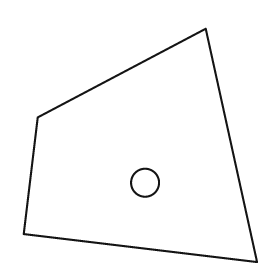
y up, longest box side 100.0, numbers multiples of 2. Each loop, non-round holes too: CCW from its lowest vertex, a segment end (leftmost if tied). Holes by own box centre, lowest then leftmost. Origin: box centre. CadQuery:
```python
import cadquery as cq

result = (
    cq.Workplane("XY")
    .moveTo(50.0, -50.0)
    .lineTo(28.0, 50.0)
    .lineTo(-44.0, 12.0)
    .lineTo(-50.0, -38.0)
    .close()
    .moveTo(2.0, -16.0)
    .circle(6.0)
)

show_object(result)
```